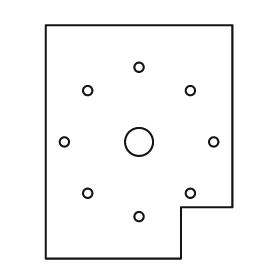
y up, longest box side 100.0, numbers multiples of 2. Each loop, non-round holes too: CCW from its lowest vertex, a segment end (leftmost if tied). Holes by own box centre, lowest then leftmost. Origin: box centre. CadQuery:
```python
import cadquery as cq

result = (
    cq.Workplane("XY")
    .moveTo(-40.0, -50.0)
    .lineTo(18.0, -50.0)
    .lineTo(18.0, -28.0)
    .lineTo(40.0, -28.0)
    .lineTo(40.0, 50.0)
    .lineTo(-40.0, 50.0)
    .close()
    .moveTo(0.0, -32.0)
    .circle(2.0)
    .moveTo(-22.0, -22.0)
    .circle(2.0)
    .moveTo(22.0, -22.0)
    .circle(2.0)
    .moveTo(-32.0, 0.0)
    .circle(2.0)
    .moveTo(0.0, 0.0)
    .circle(6.0)
    .moveTo(32.0, 0.0)
    .circle(2.0)
    .moveTo(-22.0, 22.0)
    .circle(2.0)
    .moveTo(22.0, 22.0)
    .circle(2.0)
    .moveTo(0.0, 32.0)
    .circle(2.0)
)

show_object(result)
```